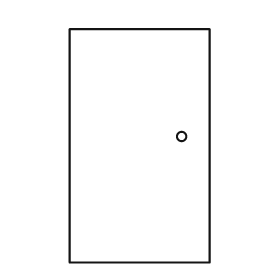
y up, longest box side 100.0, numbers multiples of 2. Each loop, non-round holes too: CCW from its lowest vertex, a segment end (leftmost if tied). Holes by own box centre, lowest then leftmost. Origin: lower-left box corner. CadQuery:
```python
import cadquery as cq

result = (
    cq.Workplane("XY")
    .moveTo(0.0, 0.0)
    .lineTo(60.0, 0.0)
    .lineTo(60.0, 100.0)
    .lineTo(0.0, 100.0)
    .close()
    .moveTo(48.0, 54.0)
    .circle(2.0)
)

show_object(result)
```